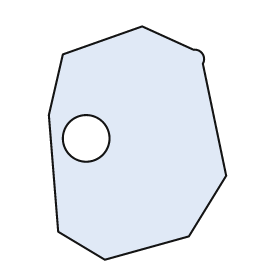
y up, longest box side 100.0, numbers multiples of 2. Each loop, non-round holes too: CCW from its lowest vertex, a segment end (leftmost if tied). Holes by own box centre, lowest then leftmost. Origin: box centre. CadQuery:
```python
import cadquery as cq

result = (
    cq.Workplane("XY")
    .moveTo(-14.0, -50.0)
    .lineTo(22.0, -40.0)
    .lineTo(38.0, -14.0)
    .lineTo(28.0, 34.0)
    .threePointArc((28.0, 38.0), (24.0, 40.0))
    .lineTo(2.0, 50.0)
    .lineTo(-32.0, 38.0)
    .lineTo(-38.0, 12.0)
    .lineTo(-34.0, -38.0)
    .close()
    .moveTo(-22.0, 2.0)
    .circle(10.0)
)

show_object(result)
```